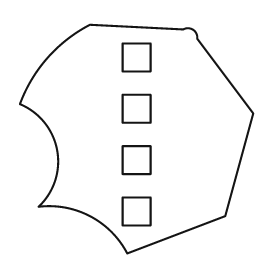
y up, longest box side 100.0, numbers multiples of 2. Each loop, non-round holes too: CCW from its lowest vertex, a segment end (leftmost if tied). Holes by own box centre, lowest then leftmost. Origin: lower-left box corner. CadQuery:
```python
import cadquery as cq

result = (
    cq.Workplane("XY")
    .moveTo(46.0, 0.0)
    .lineTo(88.0, 16.0)
    .lineTo(100.0, 60.0)
    .lineTo(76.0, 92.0)
    .threePointArc((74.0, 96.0), (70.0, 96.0))
    .lineTo(30.0, 98.0)
    .threePointArc((12.0, 84.0), (0.0, 64.0))
    .threePointArc((16.0, 44.0), (8.0, 20.0))
    .threePointArc((30.0, 16.0), (46.0, 0.0))
    .close()
    .moveTo(44.0, 12.0)
    .lineTo(56.0, 12.0)
    .lineTo(56.0, 24.0)
    .lineTo(44.0, 24.0)
    .close()
    .moveTo(44.0, 34.0)
    .lineTo(56.0, 34.0)
    .lineTo(56.0, 46.0)
    .lineTo(44.0, 46.0)
    .close()
    .moveTo(44.0, 56.0)
    .lineTo(56.0, 56.0)
    .lineTo(56.0, 68.0)
    .lineTo(44.0, 68.0)
    .close()
    .moveTo(44.0, 78.0)
    .lineTo(56.0, 78.0)
    .lineTo(56.0, 90.0)
    .lineTo(44.0, 90.0)
    .close()
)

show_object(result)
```